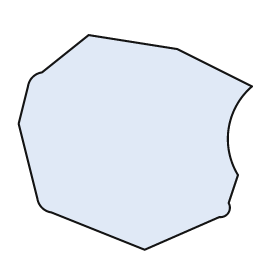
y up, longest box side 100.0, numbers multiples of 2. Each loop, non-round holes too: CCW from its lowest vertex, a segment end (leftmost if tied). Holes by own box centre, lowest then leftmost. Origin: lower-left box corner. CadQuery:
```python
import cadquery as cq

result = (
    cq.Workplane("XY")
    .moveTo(54.0, 0.0)
    .lineTo(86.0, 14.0)
    .threePointArc((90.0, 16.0), (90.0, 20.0))
    .lineTo(94.0, 32.0)
    .threePointArc((90.0, 52.0), (100.0, 70.0))
    .lineTo(68.0, 86.0)
    .lineTo(30.0, 92.0)
    .lineTo(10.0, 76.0)
    .threePointArc((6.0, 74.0), (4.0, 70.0))
    .lineTo(0.0, 54.0)
    .lineTo(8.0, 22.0)
    .threePointArc((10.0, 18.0), (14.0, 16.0))
    .close()
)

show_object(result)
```